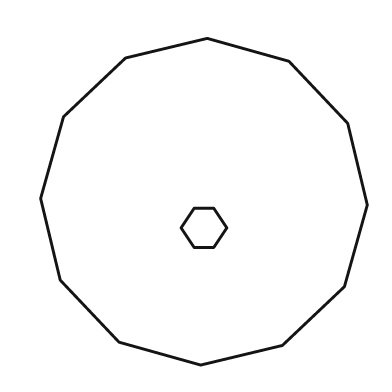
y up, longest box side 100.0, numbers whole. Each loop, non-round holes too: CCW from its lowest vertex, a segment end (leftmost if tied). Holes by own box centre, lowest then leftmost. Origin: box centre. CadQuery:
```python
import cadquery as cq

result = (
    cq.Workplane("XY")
    .moveTo(-1.0, -50.0)
    .lineTo(24.0, -44.0)
    .lineTo(43.0, -26.0)
    .lineTo(50.0, -1.0)
    .lineTo(44.0, 24.0)
    .lineTo(26.0, 43.0)
    .lineTo(1.0, 50.0)
    .lineTo(-24.0, 44.0)
    .lineTo(-43.0, 26.0)
    .lineTo(-50.0, 1.0)
    .lineTo(-44.0, -24.0)
    .lineTo(-26.0, -43.0)
    .close()
    .moveTo(-3.0, -14.0)
    .lineTo(3.0, -14.0)
    .lineTo(7.0, -8.0)
    .lineTo(3.0, -2.0)
    .lineTo(-3.0, -2.0)
    .lineTo(-7.0, -8.0)
    .close()
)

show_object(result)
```